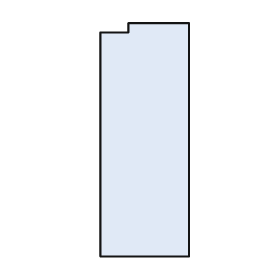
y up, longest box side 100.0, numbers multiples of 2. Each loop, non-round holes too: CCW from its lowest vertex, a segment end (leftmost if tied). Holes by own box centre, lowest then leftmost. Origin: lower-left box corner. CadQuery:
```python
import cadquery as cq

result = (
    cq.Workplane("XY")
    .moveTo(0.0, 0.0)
    .lineTo(38.0, 0.0)
    .lineTo(38.0, 100.0)
    .lineTo(12.0, 100.0)
    .lineTo(12.0, 96.0)
    .lineTo(0.0, 96.0)
    .close()
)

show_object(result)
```